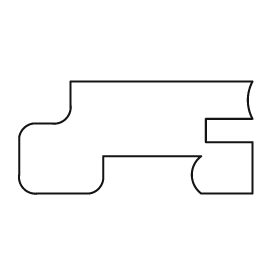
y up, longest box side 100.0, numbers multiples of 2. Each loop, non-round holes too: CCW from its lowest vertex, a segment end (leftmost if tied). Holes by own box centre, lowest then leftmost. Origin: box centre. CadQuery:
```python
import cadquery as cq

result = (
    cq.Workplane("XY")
    .moveTo(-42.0, -24.0)
    .lineTo(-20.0, -24.0)
    .threePointArc((-16.0, -22.0), (-14.0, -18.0))
    .lineTo(-14.0, -8.0)
    .lineTo(28.0, -8.0)
    .threePointArc((24.0, -16.0), (28.0, -24.0))
    .lineTo(50.0, -24.0)
    .lineTo(50.0, -2.0)
    .lineTo(30.0, -2.0)
    .lineTo(30.0, 8.0)
    .lineTo(50.0, 8.0)
    .threePointArc((48.0, 16.0), (50.0, 24.0))
    .lineTo(-28.0, 24.0)
    .lineTo(-28.0, 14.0)
    .threePointArc((-30.0, 8.0), (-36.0, 6.0))
    .lineTo(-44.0, 6.0)
    .threePointArc((-48.0, 4.0), (-50.0, 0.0))
    .lineTo(-50.0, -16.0)
    .threePointArc((-48.0, -22.0), (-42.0, -24.0))
    .close()
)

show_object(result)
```